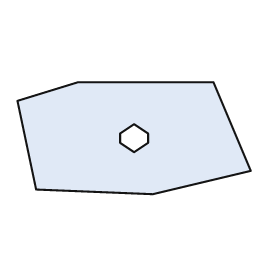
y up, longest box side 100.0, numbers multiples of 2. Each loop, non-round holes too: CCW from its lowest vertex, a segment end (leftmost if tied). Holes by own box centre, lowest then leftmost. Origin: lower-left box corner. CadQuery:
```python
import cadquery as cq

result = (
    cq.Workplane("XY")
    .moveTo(58.0, 0.0)
    .lineTo(100.0, 10.0)
    .lineTo(84.0, 48.0)
    .lineTo(26.0, 48.0)
    .lineTo(0.0, 40.0)
    .lineTo(8.0, 2.0)
    .close()
    .moveTo(50.0, 18.0)
    .lineTo(56.0, 22.0)
    .lineTo(56.0, 26.0)
    .lineTo(50.0, 30.0)
    .lineTo(44.0, 26.0)
    .lineTo(44.0, 22.0)
    .close()
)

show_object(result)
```